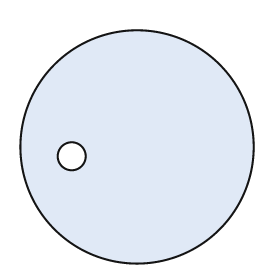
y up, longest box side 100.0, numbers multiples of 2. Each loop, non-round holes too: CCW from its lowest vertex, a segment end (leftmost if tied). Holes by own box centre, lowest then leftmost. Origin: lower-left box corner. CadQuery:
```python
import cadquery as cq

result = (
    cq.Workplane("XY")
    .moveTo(50.0, 50.0)
    .circle(50.0)
    .moveTo(22.0, 46.0)
    .circle(6.0)
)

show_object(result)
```